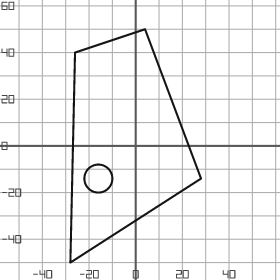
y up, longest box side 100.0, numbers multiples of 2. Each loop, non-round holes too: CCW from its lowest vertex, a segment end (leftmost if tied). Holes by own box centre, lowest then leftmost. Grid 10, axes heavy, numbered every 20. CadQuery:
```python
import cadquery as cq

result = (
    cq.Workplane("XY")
    .moveTo(-28.0, -50.0)
    .lineTo(28.0, -14.0)
    .lineTo(4.0, 50.0)
    .lineTo(-26.0, 40.0)
    .close()
    .moveTo(-16.0, -14.0)
    .circle(6.0)
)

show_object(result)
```